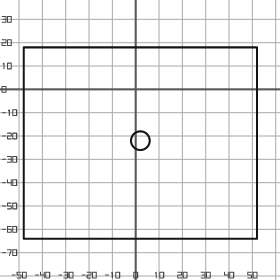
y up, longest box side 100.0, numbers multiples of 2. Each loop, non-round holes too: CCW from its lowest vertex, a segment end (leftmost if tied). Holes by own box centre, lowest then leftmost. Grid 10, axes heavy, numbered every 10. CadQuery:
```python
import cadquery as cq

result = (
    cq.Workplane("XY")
    .moveTo(-48.0, -64.0)
    .lineTo(52.0, -64.0)
    .lineTo(52.0, 18.0)
    .lineTo(-48.0, 18.0)
    .close()
    .moveTo(2.0, -22.0)
    .circle(4.0)
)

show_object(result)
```